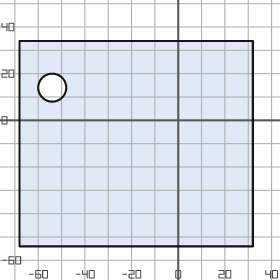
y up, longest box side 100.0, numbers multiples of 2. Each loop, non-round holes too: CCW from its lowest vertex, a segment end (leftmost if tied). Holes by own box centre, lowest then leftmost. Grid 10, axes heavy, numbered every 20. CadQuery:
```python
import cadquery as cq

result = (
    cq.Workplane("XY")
    .moveTo(-68.0, -54.0)
    .lineTo(32.0, -54.0)
    .lineTo(32.0, 34.0)
    .lineTo(-68.0, 34.0)
    .close()
    .moveTo(-54.0, 14.0)
    .circle(6.0)
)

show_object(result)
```